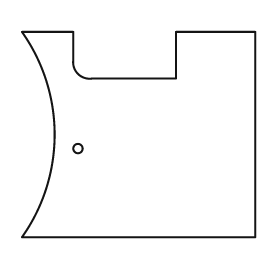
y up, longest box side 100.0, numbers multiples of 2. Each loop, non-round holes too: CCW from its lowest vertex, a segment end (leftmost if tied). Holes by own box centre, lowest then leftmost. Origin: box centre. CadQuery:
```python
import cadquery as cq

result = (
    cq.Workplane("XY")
    .moveTo(-50.0, -44.0)
    .lineTo(50.0, -44.0)
    .lineTo(50.0, 44.0)
    .lineTo(16.0, 44.0)
    .lineTo(16.0, 24.0)
    .lineTo(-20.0, 24.0)
    .threePointArc((-26.0, 26.0), (-28.0, 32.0))
    .lineTo(-28.0, 44.0)
    .lineTo(-50.0, 44.0)
    .threePointArc((-36.0, 0.0), (-50.0, -44.0))
    .close()
    .moveTo(-26.0, -6.0)
    .circle(2.0)
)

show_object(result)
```